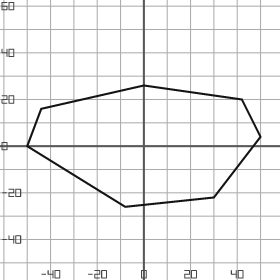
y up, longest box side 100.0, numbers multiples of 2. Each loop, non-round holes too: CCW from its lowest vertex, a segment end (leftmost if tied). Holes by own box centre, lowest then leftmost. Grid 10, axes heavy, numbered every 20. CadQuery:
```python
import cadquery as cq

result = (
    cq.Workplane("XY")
    .moveTo(-8.0, -26.0)
    .lineTo(30.0, -22.0)
    .lineTo(50.0, 4.0)
    .lineTo(42.0, 20.0)
    .lineTo(0.0, 26.0)
    .lineTo(-44.0, 16.0)
    .lineTo(-50.0, 0.0)
    .close()
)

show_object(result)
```